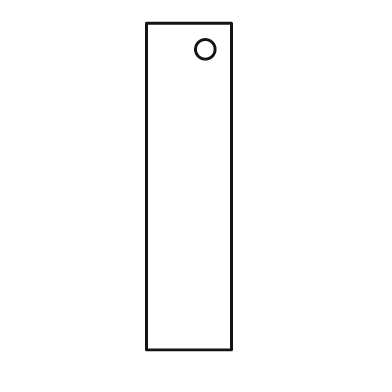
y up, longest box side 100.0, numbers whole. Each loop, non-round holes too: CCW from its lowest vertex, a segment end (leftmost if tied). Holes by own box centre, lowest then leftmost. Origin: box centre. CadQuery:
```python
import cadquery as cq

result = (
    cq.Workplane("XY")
    .moveTo(-13.0, -50.0)
    .lineTo(13.0, -50.0)
    .lineTo(13.0, 50.0)
    .lineTo(-13.0, 50.0)
    .close()
    .moveTo(5.0, 42.0)
    .circle(3.0)
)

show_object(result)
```